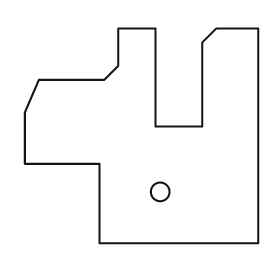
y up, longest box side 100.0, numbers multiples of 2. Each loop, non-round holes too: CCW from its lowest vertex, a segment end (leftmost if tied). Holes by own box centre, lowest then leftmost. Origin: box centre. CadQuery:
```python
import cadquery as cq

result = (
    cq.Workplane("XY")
    .moveTo(-18.0, -46.0)
    .lineTo(50.0, -46.0)
    .lineTo(50.0, 46.0)
    .lineTo(32.0, 46.0)
    .lineTo(26.0, 40.0)
    .lineTo(26.0, 4.0)
    .lineTo(6.0, 4.0)
    .lineTo(6.0, 46.0)
    .lineTo(-10.0, 46.0)
    .lineTo(-10.0, 30.0)
    .lineTo(-16.0, 24.0)
    .lineTo(-44.0, 24.0)
    .lineTo(-50.0, 10.0)
    .lineTo(-50.0, -12.0)
    .lineTo(-18.0, -12.0)
    .close()
    .moveTo(8.0, -24.0)
    .circle(4.0)
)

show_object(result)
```